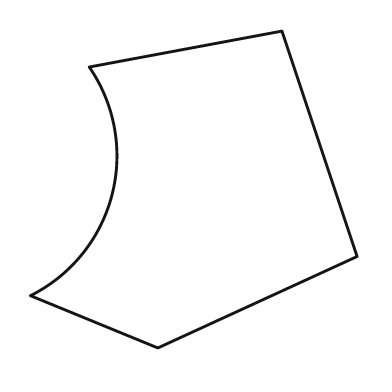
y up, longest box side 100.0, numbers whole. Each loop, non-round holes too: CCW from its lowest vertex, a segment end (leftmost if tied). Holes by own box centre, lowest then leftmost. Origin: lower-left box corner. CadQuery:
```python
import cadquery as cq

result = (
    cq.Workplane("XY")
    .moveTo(39.0, 0.0)
    .lineTo(100.0, 28.0)
    .lineTo(77.0, 97.0)
    .lineTo(18.0, 86.0)
    .threePointArc((25.0, 47.0), (0.0, 16.0))
    .close()
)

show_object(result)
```